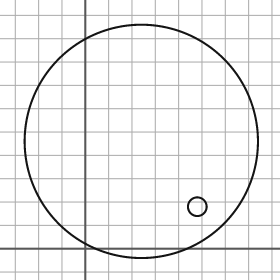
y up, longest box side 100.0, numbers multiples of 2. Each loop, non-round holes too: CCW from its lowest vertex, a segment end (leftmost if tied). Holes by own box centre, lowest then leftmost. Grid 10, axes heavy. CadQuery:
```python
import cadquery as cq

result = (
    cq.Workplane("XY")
    .moveTo(24.0, 46.0)
    .circle(50.0)
    .moveTo(48.0, 18.0)
    .circle(4.0)
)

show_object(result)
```